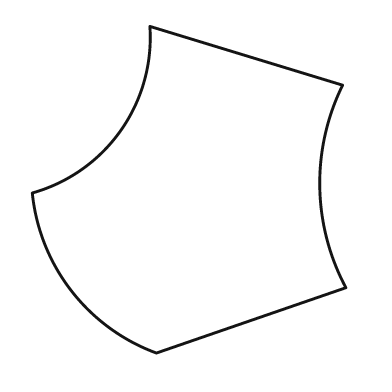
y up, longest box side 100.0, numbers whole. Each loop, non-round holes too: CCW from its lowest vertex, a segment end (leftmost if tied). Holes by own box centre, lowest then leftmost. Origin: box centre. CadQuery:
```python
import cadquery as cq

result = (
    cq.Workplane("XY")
    .moveTo(-10.0, -50.0)
    .lineTo(48.0, -30.0)
    .threePointArc((40.0, 1.0), (47.0, 32.0))
    .lineTo(-12.0, 50.0)
    .threePointArc((-21.0, 18.0), (-48.0, -1.0))
    .threePointArc((-36.0, -31.0), (-10.0, -50.0))
    .close()
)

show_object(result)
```